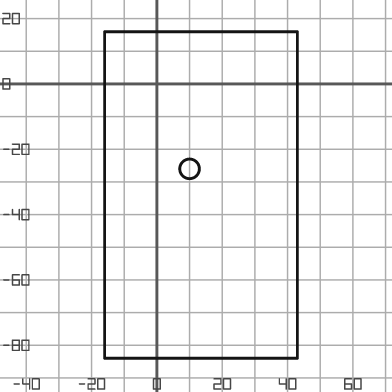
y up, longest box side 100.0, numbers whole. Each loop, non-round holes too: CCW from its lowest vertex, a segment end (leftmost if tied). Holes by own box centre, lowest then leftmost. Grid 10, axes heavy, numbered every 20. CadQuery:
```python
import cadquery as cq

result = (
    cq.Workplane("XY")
    .moveTo(-16.0, -84.0)
    .lineTo(43.0, -84.0)
    .lineTo(43.0, 16.0)
    .lineTo(-16.0, 16.0)
    .close()
    .moveTo(10.0, -26.0)
    .circle(3.0)
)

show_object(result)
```